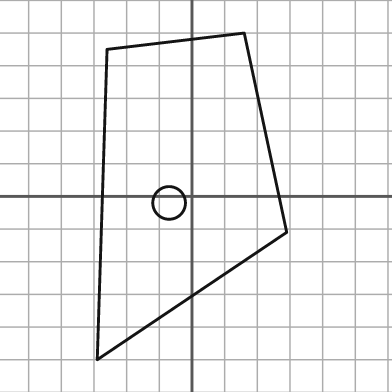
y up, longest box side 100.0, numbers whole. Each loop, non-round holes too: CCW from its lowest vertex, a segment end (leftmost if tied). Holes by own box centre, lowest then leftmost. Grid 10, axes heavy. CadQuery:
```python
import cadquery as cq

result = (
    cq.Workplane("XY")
    .moveTo(-29.0, -50.0)
    .lineTo(29.0, -11.0)
    .lineTo(16.0, 50.0)
    .lineTo(-26.0, 45.0)
    .close()
    .moveTo(-7.0, -2.0)
    .circle(5.0)
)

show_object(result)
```